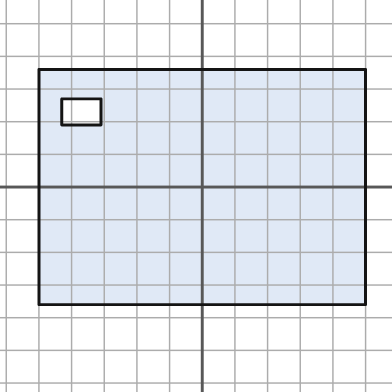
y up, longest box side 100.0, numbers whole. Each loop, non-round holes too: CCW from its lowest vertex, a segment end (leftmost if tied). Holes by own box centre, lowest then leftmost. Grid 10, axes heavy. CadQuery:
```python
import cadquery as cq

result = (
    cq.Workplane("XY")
    .moveTo(-50.0, -36.0)
    .lineTo(50.0, -36.0)
    .lineTo(50.0, 36.0)
    .lineTo(-50.0, 36.0)
    .close()
    .moveTo(-43.0, 19.0)
    .lineTo(-31.0, 19.0)
    .lineTo(-31.0, 27.0)
    .lineTo(-43.0, 27.0)
    .close()
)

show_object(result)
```